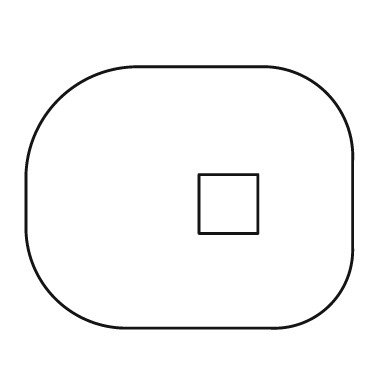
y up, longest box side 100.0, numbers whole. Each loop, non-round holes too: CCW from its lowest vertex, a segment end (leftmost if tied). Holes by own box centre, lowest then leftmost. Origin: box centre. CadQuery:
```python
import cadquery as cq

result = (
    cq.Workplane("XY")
    .moveTo(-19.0, -40.0)
    .lineTo(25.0, -40.0)
    .threePointArc((43.0, -33.0), (50.0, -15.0))
    .lineTo(50.0, 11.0)
    .threePointArc((42.0, 32.0), (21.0, 40.0))
    .lineTo(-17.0, 40.0)
    .threePointArc((-40.0, 30.0), (-50.0, 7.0))
    .lineTo(-50.0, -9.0)
    .threePointArc((-41.0, -31.0), (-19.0, -40.0))
    .close()
    .moveTo(3.0, -11.0)
    .lineTo(21.0, -11.0)
    .lineTo(21.0, 7.0)
    .lineTo(3.0, 7.0)
    .close()
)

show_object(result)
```